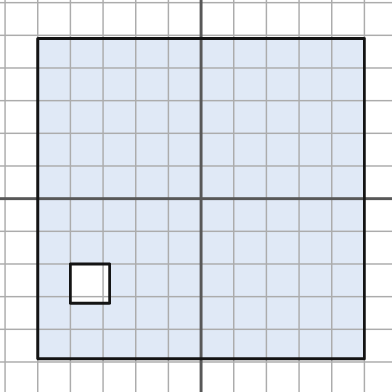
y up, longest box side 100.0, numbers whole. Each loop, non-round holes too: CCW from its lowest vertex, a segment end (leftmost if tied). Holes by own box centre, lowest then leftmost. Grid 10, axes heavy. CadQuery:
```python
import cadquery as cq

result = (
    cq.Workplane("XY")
    .moveTo(-50.0, -49.0)
    .lineTo(50.0, -49.0)
    .lineTo(50.0, 49.0)
    .lineTo(-50.0, 49.0)
    .close()
    .moveTo(-40.0, -32.0)
    .lineTo(-28.0, -32.0)
    .lineTo(-28.0, -20.0)
    .lineTo(-40.0, -20.0)
    .close()
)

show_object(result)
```